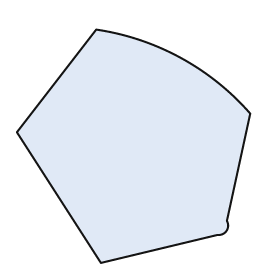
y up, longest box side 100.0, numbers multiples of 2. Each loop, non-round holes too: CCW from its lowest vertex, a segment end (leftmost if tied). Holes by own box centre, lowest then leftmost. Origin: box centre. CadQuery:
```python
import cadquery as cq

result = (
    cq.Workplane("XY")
    .moveTo(-14.0, -50.0)
    .lineTo(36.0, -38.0)
    .threePointArc((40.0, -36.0), (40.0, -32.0))
    .lineTo(50.0, 14.0)
    .threePointArc((20.0, 38.0), (-16.0, 50.0))
    .lineTo(-50.0, 6.0)
    .close()
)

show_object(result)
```